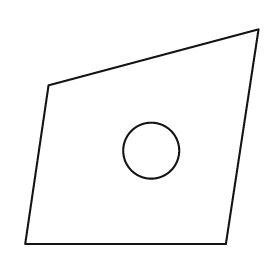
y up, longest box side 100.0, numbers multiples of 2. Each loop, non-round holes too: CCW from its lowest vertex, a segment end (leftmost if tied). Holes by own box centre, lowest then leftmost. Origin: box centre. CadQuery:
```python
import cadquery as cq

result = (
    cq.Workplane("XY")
    .moveTo(-50.0, -46.0)
    .lineTo(36.0, -46.0)
    .lineTo(50.0, 46.0)
    .lineTo(-40.0, 22.0)
    .close()
    .moveTo(4.0, -6.0)
    .circle(12.0)
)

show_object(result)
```